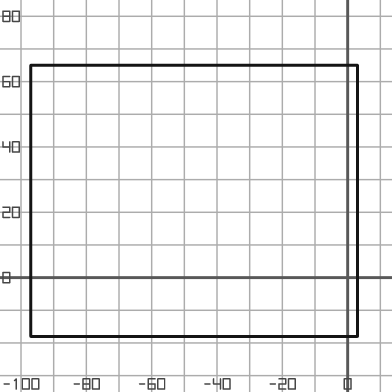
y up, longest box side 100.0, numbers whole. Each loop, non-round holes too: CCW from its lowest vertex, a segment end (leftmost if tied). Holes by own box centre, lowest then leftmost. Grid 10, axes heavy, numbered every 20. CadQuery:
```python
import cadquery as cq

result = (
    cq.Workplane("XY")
    .moveTo(-97.0, -18.0)
    .lineTo(3.0, -18.0)
    .lineTo(3.0, 65.0)
    .lineTo(-97.0, 65.0)
    .close()
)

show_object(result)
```